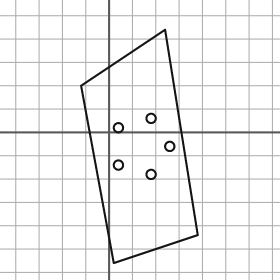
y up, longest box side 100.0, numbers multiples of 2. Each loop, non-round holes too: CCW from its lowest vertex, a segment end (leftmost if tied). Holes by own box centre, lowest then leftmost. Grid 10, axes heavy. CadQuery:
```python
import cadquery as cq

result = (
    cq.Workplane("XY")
    .moveTo(2.0, -56.0)
    .lineTo(38.0, -44.0)
    .lineTo(24.0, 44.0)
    .lineTo(-12.0, 20.0)
    .close()
    .moveTo(18.0, -18.0)
    .circle(2.0)
    .moveTo(4.0, -14.0)
    .circle(2.0)
    .moveTo(26.0, -6.0)
    .circle(2.0)
    .moveTo(4.0, 2.0)
    .circle(2.0)
    .moveTo(18.0, 6.0)
    .circle(2.0)
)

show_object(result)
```